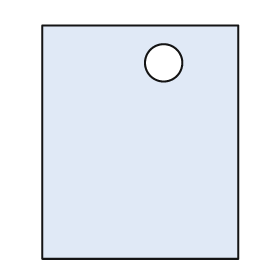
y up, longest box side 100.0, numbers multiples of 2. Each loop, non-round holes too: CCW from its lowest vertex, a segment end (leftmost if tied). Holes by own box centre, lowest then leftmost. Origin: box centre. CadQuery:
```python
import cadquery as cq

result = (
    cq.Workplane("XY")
    .moveTo(-42.0, -50.0)
    .lineTo(42.0, -50.0)
    .lineTo(42.0, 50.0)
    .lineTo(-42.0, 50.0)
    .close()
    .moveTo(10.0, 34.0)
    .circle(8.0)
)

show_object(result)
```